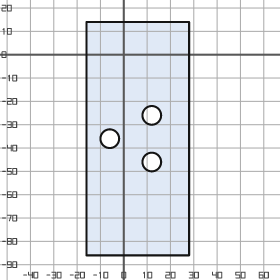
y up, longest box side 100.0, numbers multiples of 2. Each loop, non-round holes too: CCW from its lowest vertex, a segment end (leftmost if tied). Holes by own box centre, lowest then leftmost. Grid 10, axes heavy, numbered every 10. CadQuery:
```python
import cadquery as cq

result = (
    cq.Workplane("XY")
    .moveTo(-16.0, -86.0)
    .lineTo(28.0, -86.0)
    .lineTo(28.0, 14.0)
    .lineTo(-16.0, 14.0)
    .close()
    .moveTo(12.0, -46.0)
    .circle(4.0)
    .moveTo(-6.0, -36.0)
    .circle(4.0)
    .moveTo(12.0, -26.0)
    .circle(4.0)
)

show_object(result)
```